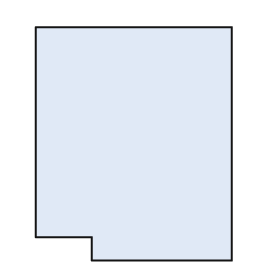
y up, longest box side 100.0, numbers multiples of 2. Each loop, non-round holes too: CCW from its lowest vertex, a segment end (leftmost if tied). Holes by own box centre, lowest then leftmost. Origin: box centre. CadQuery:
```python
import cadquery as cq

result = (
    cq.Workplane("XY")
    .moveTo(-18.0, -50.0)
    .lineTo(42.0, -50.0)
    .lineTo(42.0, 50.0)
    .lineTo(-42.0, 50.0)
    .lineTo(-42.0, -40.0)
    .lineTo(-18.0, -40.0)
    .close()
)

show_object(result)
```